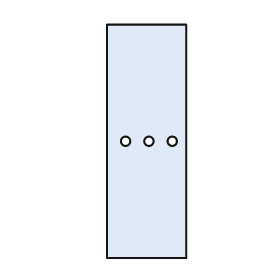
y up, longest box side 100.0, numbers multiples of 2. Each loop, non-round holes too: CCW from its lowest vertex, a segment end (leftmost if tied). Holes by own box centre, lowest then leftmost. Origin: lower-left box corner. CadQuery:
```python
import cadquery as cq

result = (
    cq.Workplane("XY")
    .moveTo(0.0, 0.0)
    .lineTo(34.0, 0.0)
    .lineTo(34.0, 100.0)
    .lineTo(0.0, 100.0)
    .close()
    .moveTo(8.0, 50.0)
    .circle(2.0)
    .moveTo(18.0, 50.0)
    .circle(2.0)
    .moveTo(28.0, 50.0)
    .circle(2.0)
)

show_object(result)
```